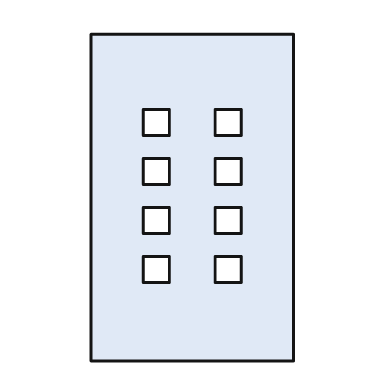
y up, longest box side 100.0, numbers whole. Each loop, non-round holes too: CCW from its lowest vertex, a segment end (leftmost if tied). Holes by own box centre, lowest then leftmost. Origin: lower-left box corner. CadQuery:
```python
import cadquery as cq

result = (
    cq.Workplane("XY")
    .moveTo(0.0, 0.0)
    .lineTo(62.0, 0.0)
    .lineTo(62.0, 100.0)
    .lineTo(0.0, 100.0)
    .close()
    .moveTo(16.0, 24.0)
    .lineTo(24.0, 24.0)
    .lineTo(24.0, 32.0)
    .lineTo(16.0, 32.0)
    .close()
    .moveTo(38.0, 24.0)
    .lineTo(46.0, 24.0)
    .lineTo(46.0, 32.0)
    .lineTo(38.0, 32.0)
    .close()
    .moveTo(16.0, 39.0)
    .lineTo(24.0, 39.0)
    .lineTo(24.0, 47.0)
    .lineTo(16.0, 47.0)
    .close()
    .moveTo(38.0, 39.0)
    .lineTo(46.0, 39.0)
    .lineTo(46.0, 47.0)
    .lineTo(38.0, 47.0)
    .close()
    .moveTo(16.0, 54.0)
    .lineTo(24.0, 54.0)
    .lineTo(24.0, 62.0)
    .lineTo(16.0, 62.0)
    .close()
    .moveTo(38.0, 54.0)
    .lineTo(46.0, 54.0)
    .lineTo(46.0, 62.0)
    .lineTo(38.0, 62.0)
    .close()
    .moveTo(16.0, 69.0)
    .lineTo(24.0, 69.0)
    .lineTo(24.0, 77.0)
    .lineTo(16.0, 77.0)
    .close()
    .moveTo(38.0, 69.0)
    .lineTo(46.0, 69.0)
    .lineTo(46.0, 77.0)
    .lineTo(38.0, 77.0)
    .close()
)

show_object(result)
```